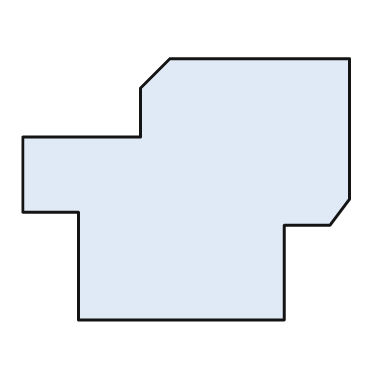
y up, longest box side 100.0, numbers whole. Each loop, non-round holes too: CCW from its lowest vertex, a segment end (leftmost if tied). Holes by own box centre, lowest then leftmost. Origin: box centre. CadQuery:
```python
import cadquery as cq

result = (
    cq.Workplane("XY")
    .moveTo(-33.0, -40.0)
    .lineTo(30.0, -40.0)
    .lineTo(30.0, -11.0)
    .lineTo(44.0, -11.0)
    .lineTo(50.0, -3.0)
    .lineTo(50.0, 40.0)
    .lineTo(-5.0, 40.0)
    .lineTo(-14.0, 31.0)
    .lineTo(-14.0, 16.0)
    .lineTo(-50.0, 16.0)
    .lineTo(-50.0, -7.0)
    .lineTo(-33.0, -7.0)
    .close()
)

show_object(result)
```